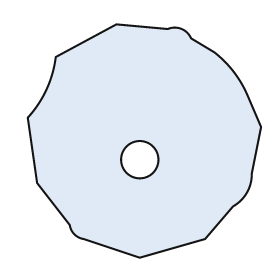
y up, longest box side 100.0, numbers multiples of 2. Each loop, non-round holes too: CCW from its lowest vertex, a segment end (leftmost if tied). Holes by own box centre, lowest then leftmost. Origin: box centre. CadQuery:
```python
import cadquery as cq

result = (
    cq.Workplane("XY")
    .moveTo(-2.0, -50.0)
    .lineTo(26.0, -42.0)
    .lineTo(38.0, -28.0)
    .threePointArc((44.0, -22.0), (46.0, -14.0))
    .lineTo(50.0, 6.0)
    .lineTo(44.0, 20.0)
    .threePointArc((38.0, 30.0), (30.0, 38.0))
    .lineTo(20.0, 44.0)
    .threePointArc((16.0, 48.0), (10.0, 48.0))
    .lineTo(-12.0, 50.0)
    .lineTo(-38.0, 36.0)
    .threePointArc((-42.0, 22.0), (-50.0, 10.0))
    .lineTo(-46.0, -18.0)
    .lineTo(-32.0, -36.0)
    .threePointArc((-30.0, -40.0), (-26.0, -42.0))
    .close()
    .moveTo(-2.0, -8.0)
    .circle(8.0)
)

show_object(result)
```